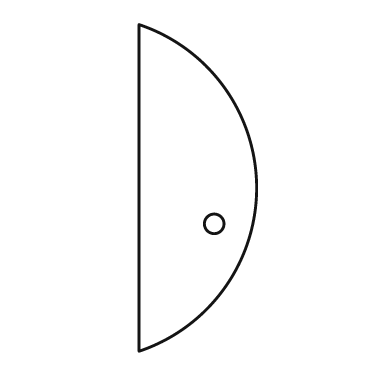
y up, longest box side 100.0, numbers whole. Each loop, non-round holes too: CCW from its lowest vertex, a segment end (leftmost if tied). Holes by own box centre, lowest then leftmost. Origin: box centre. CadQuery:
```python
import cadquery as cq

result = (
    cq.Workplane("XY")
    .moveTo(-18.0, -50.0)
    .threePointArc((18.0, 0.0), (-18.0, 50.0))
    .close()
    .moveTo(5.0, -11.0)
    .circle(3.0)
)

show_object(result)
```